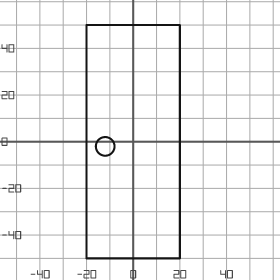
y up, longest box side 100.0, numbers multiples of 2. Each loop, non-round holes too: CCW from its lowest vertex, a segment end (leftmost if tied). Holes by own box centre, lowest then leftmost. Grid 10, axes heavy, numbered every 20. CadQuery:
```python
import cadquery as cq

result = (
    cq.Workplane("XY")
    .moveTo(-20.0, -50.0)
    .lineTo(20.0, -50.0)
    .lineTo(20.0, 50.0)
    .lineTo(-20.0, 50.0)
    .close()
    .moveTo(-12.0, -2.0)
    .circle(4.0)
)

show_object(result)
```